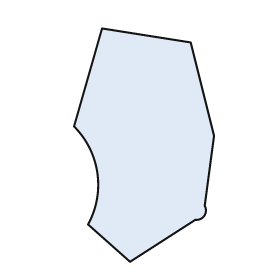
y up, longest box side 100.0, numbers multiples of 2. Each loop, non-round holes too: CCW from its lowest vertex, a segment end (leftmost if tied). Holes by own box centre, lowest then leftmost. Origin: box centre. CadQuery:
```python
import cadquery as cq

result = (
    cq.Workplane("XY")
    .moveTo(-6.0, -50.0)
    .lineTo(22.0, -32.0)
    .threePointArc((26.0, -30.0), (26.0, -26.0))
    .lineTo(30.0, 4.0)
    .lineTo(20.0, 44.0)
    .lineTo(-18.0, 50.0)
    .lineTo(-30.0, 8.0)
    .threePointArc((-20.0, -12.0), (-24.0, -34.0))
    .close()
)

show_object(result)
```